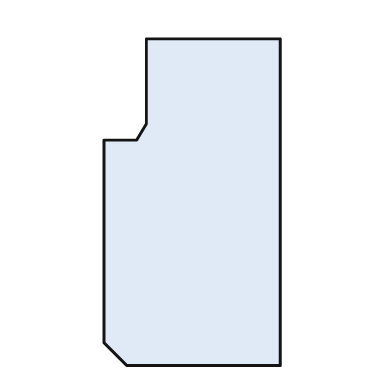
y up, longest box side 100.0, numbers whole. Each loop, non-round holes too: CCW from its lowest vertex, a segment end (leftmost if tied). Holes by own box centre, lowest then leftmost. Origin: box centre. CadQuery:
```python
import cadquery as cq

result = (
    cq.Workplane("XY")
    .moveTo(-20.0, -50.0)
    .lineTo(27.0, -50.0)
    .lineTo(27.0, 50.0)
    .lineTo(-14.0, 50.0)
    .lineTo(-14.0, 24.0)
    .lineTo(-17.0, 19.0)
    .lineTo(-27.0, 19.0)
    .lineTo(-27.0, -43.0)
    .close()
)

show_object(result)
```